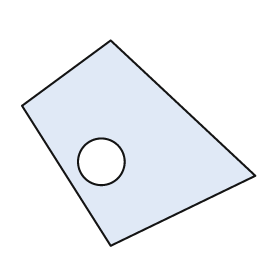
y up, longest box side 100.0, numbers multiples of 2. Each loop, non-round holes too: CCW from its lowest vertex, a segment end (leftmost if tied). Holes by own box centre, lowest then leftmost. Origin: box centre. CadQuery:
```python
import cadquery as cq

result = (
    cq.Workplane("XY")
    .moveTo(-12.0, -44.0)
    .lineTo(50.0, -14.0)
    .lineTo(-12.0, 44.0)
    .lineTo(-50.0, 16.0)
    .close()
    .moveTo(-16.0, -8.0)
    .circle(10.0)
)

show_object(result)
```